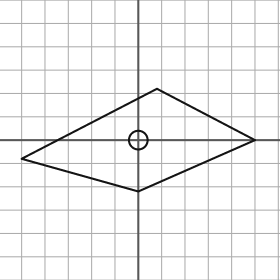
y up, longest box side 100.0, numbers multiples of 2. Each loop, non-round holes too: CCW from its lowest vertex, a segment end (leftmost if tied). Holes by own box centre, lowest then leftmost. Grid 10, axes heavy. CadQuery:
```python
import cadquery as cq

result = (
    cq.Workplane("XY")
    .moveTo(0.0, -22.0)
    .lineTo(50.0, 0.0)
    .lineTo(8.0, 22.0)
    .lineTo(-50.0, -8.0)
    .close()
    .moveTo(0.0, 0.0)
    .circle(4.0)
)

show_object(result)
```